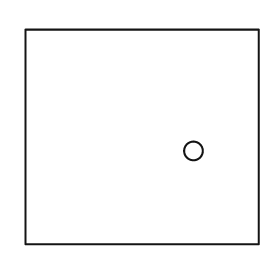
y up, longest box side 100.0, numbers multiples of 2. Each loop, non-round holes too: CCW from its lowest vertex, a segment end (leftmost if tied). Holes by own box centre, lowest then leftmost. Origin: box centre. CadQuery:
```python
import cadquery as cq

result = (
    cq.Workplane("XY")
    .moveTo(-50.0, -46.0)
    .lineTo(50.0, -46.0)
    .lineTo(50.0, 46.0)
    .lineTo(-50.0, 46.0)
    .close()
    .moveTo(22.0, -6.0)
    .circle(4.0)
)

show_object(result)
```